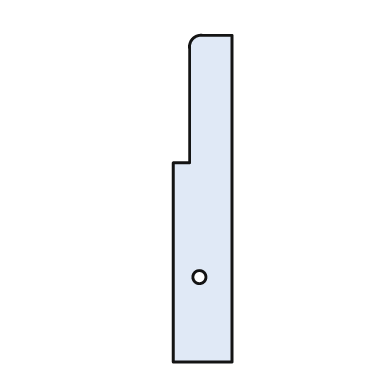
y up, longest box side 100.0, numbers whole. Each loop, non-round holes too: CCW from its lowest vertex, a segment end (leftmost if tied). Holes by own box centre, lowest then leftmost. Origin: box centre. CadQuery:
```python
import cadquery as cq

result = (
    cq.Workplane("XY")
    .moveTo(-9.0, -50.0)
    .lineTo(9.0, -50.0)
    .lineTo(9.0, 50.0)
    .lineTo(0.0, 50.0)
    .threePointArc((-3.0, 49.0), (-4.0, 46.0))
    .lineTo(-4.0, 11.0)
    .lineTo(-9.0, 11.0)
    .close()
    .moveTo(-1.0, -24.0)
    .circle(2.0)
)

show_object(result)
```